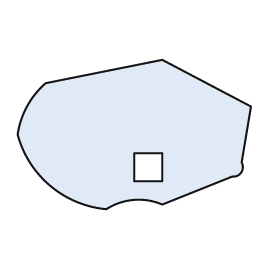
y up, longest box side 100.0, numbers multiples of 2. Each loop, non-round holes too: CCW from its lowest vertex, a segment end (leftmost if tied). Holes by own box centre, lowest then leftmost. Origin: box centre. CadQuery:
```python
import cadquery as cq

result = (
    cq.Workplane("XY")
    .moveTo(-12.0, -32.0)
    .threePointArc((0.0, -28.0), (12.0, -30.0))
    .lineTo(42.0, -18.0)
    .threePointArc((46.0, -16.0), (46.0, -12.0))
    .lineTo(50.0, 12.0)
    .lineTo(12.0, 32.0)
    .lineTo(-38.0, 22.0)
    .threePointArc((-46.0, 12.0), (-50.0, 0.0))
    .threePointArc((-36.0, -22.0), (-12.0, -32.0))
    .close()
    .moveTo(0.0, -20.0)
    .lineTo(12.0, -20.0)
    .lineTo(12.0, -8.0)
    .lineTo(0.0, -8.0)
    .close()
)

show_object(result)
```